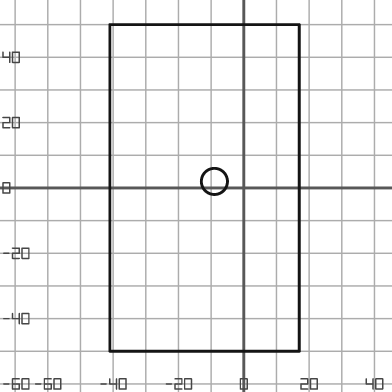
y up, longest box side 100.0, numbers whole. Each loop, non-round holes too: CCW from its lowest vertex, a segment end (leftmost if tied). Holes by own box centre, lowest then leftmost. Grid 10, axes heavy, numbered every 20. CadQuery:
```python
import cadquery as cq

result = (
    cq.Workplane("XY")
    .moveTo(-41.0, -50.0)
    .lineTo(17.0, -50.0)
    .lineTo(17.0, 50.0)
    .lineTo(-41.0, 50.0)
    .close()
    .moveTo(-9.0, 2.0)
    .circle(4.0)
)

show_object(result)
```